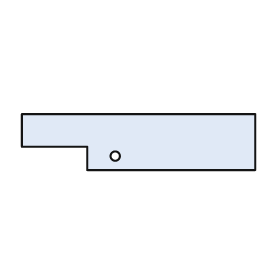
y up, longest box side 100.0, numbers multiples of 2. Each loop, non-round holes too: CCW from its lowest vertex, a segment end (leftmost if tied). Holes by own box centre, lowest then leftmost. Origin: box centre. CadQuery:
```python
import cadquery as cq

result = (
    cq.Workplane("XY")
    .moveTo(-22.0, -12.0)
    .lineTo(50.0, -12.0)
    .lineTo(50.0, 12.0)
    .lineTo(-50.0, 12.0)
    .lineTo(-50.0, -2.0)
    .lineTo(-22.0, -2.0)
    .close()
    .moveTo(-10.0, -6.0)
    .circle(2.0)
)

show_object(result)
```